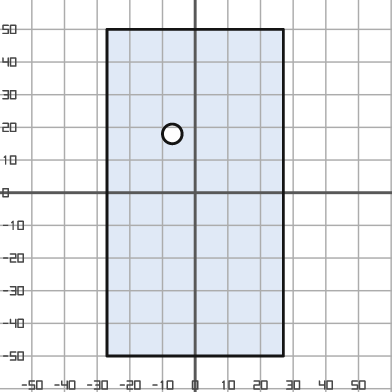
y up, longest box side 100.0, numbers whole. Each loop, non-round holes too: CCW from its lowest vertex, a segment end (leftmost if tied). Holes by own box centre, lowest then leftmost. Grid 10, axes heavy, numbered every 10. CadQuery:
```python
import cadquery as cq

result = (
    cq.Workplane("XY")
    .moveTo(-27.0, -50.0)
    .lineTo(27.0, -50.0)
    .lineTo(27.0, 50.0)
    .lineTo(-27.0, 50.0)
    .close()
    .moveTo(-7.0, 18.0)
    .circle(3.0)
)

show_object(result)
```